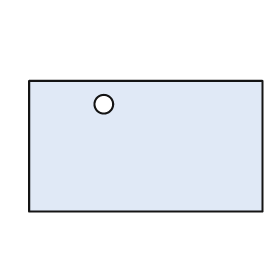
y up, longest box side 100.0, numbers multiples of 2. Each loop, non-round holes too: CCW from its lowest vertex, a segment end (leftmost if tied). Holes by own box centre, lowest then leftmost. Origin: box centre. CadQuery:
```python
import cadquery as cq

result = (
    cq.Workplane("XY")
    .moveTo(-50.0, -28.0)
    .lineTo(50.0, -28.0)
    .lineTo(50.0, 28.0)
    .lineTo(-50.0, 28.0)
    .close()
    .moveTo(-18.0, 18.0)
    .circle(4.0)
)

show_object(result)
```